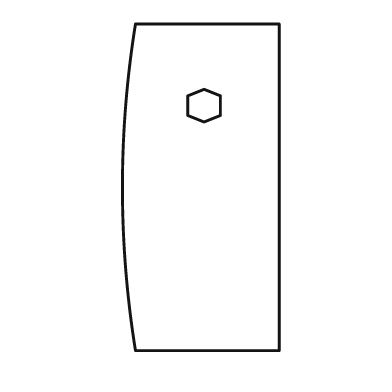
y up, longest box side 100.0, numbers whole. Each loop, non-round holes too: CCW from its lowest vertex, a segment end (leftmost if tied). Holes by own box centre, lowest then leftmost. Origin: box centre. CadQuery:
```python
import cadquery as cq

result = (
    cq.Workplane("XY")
    .moveTo(-20.0, -50.0)
    .lineTo(24.0, -50.0)
    .lineTo(24.0, 50.0)
    .lineTo(-20.0, 50.0)
    .threePointArc((-24.0, 0.0), (-20.0, -50.0))
    .close()
    .moveTo(1.0, 20.0)
    .lineTo(6.0, 22.0)
    .lineTo(6.0, 28.0)
    .lineTo(1.0, 30.0)
    .lineTo(-4.0, 28.0)
    .lineTo(-4.0, 22.0)
    .close()
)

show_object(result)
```